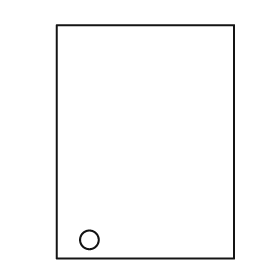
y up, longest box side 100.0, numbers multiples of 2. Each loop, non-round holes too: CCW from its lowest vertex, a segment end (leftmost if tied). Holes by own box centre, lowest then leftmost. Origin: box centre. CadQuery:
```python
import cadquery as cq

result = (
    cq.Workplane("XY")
    .moveTo(-38.0, -50.0)
    .lineTo(38.0, -50.0)
    .lineTo(38.0, 50.0)
    .lineTo(-38.0, 50.0)
    .close()
    .moveTo(-24.0, -42.0)
    .circle(4.0)
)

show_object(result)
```